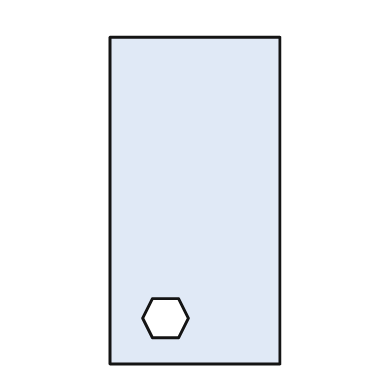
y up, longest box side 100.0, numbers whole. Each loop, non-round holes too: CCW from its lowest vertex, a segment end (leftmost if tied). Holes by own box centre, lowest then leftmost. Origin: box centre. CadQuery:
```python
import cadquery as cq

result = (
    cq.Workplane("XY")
    .moveTo(-26.0, -50.0)
    .lineTo(26.0, -50.0)
    .lineTo(26.0, 50.0)
    .lineTo(-26.0, 50.0)
    .close()
    .moveTo(-13.0, -42.0)
    .lineTo(-5.0, -42.0)
    .lineTo(-2.0, -36.0)
    .lineTo(-5.0, -30.0)
    .lineTo(-13.0, -30.0)
    .lineTo(-16.0, -36.0)
    .close()
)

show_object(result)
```